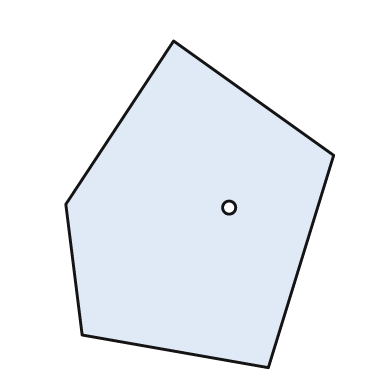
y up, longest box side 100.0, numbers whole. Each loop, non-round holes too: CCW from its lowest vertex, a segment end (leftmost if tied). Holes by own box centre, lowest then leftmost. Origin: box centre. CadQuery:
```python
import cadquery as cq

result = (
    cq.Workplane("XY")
    .moveTo(21.0, -50.0)
    .lineTo(41.0, 15.0)
    .lineTo(-8.0, 50.0)
    .lineTo(-41.0, 0.0)
    .lineTo(-36.0, -40.0)
    .close()
    .moveTo(9.0, -1.0)
    .circle(2.0)
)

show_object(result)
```